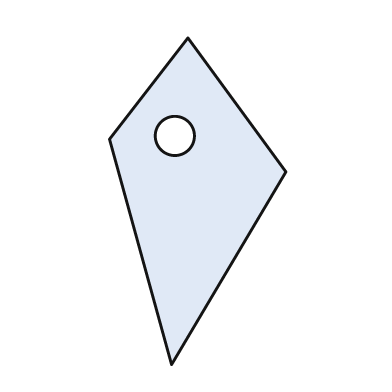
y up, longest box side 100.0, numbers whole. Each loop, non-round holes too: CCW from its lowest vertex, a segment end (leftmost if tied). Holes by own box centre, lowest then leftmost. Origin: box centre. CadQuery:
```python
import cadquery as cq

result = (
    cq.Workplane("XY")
    .moveTo(-8.0, -50.0)
    .lineTo(27.0, 9.0)
    .lineTo(-3.0, 50.0)
    .lineTo(-27.0, 19.0)
    .close()
    .moveTo(-7.0, 20.0)
    .circle(6.0)
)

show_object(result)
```